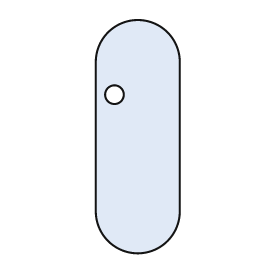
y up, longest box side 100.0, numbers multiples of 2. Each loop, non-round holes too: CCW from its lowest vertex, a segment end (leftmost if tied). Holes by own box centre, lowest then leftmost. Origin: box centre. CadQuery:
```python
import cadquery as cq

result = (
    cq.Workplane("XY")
    .moveTo(-18.0, -32.0)
    .threePointArc((0.0, -50.0), (18.0, -32.0))
    .lineTo(18.0, 32.0)
    .threePointArc((0.0, 50.0), (-18.0, 32.0))
    .close()
    .moveTo(-10.0, 18.0)
    .circle(4.0)
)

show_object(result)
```